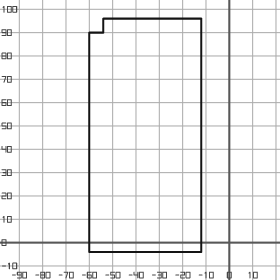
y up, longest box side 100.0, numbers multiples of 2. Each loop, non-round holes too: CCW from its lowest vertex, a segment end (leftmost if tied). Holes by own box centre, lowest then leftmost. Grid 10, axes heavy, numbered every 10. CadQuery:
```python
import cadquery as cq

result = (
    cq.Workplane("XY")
    .moveTo(-60.0, -4.0)
    .lineTo(-12.0, -4.0)
    .lineTo(-12.0, 96.0)
    .lineTo(-54.0, 96.0)
    .lineTo(-54.0, 90.0)
    .lineTo(-60.0, 90.0)
    .close()
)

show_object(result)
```